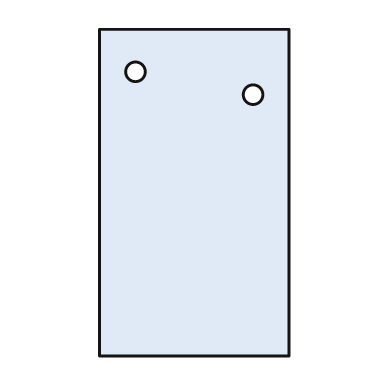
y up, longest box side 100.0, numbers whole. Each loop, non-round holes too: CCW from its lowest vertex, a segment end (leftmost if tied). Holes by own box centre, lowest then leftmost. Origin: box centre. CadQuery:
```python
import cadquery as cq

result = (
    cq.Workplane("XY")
    .moveTo(-29.0, -50.0)
    .lineTo(29.0, -50.0)
    .lineTo(29.0, 50.0)
    .lineTo(-29.0, 50.0)
    .close()
    .moveTo(18.0, 30.0)
    .circle(3.0)
    .moveTo(-18.0, 37.0)
    .circle(3.0)
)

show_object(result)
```